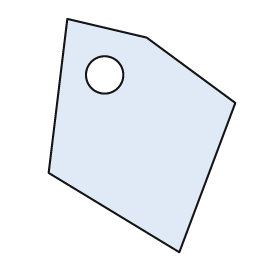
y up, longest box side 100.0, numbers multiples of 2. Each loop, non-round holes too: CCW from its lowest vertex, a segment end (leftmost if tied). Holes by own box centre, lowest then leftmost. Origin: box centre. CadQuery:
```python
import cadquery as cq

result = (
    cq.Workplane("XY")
    .moveTo(16.0, -50.0)
    .lineTo(40.0, 14.0)
    .lineTo(2.0, 42.0)
    .lineTo(-32.0, 50.0)
    .lineTo(-40.0, -16.0)
    .close()
    .moveTo(-16.0, 26.0)
    .circle(8.0)
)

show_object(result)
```